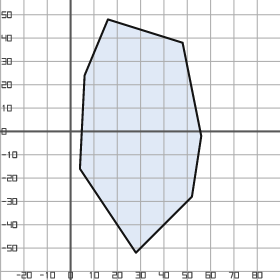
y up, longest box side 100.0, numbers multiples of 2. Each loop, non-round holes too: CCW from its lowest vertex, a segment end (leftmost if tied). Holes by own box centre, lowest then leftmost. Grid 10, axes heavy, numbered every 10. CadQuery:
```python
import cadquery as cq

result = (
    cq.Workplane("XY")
    .moveTo(28.0, -52.0)
    .lineTo(52.0, -28.0)
    .lineTo(56.0, -2.0)
    .lineTo(48.0, 38.0)
    .lineTo(16.0, 48.0)
    .lineTo(6.0, 24.0)
    .lineTo(4.0, -16.0)
    .close()
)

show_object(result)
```